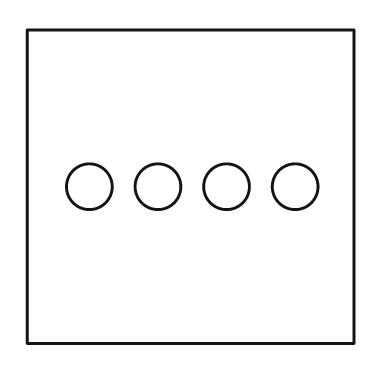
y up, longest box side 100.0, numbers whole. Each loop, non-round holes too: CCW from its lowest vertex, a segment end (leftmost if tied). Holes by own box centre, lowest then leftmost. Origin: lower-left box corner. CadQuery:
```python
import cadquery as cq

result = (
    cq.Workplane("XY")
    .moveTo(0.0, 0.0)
    .lineTo(100.0, 0.0)
    .lineTo(100.0, 96.0)
    .lineTo(0.0, 96.0)
    .close()
    .moveTo(19.0, 48.0)
    .circle(7.0)
    .moveTo(40.0, 48.0)
    .circle(7.0)
    .moveTo(61.0, 48.0)
    .circle(7.0)
    .moveTo(82.0, 48.0)
    .circle(7.0)
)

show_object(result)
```